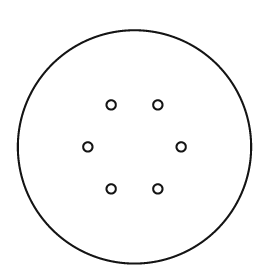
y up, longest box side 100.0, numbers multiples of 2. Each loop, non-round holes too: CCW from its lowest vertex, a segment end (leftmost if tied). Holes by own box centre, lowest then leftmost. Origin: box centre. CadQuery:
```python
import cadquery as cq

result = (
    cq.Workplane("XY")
    .moveTo(0.0, 0.0)
    .circle(50.0)
    .moveTo(-10.0, -18.0)
    .circle(2.0)
    .moveTo(10.0, -18.0)
    .circle(2.0)
    .moveTo(-20.0, 0.0)
    .circle(2.0)
    .moveTo(20.0, 0.0)
    .circle(2.0)
    .moveTo(-10.0, 18.0)
    .circle(2.0)
    .moveTo(10.0, 18.0)
    .circle(2.0)
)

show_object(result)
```